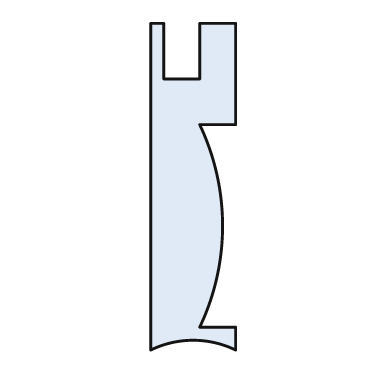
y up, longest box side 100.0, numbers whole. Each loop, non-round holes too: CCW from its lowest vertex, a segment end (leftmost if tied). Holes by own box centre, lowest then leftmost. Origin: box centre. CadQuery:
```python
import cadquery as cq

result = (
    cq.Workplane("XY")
    .moveTo(-13.0, -50.0)
    .threePointArc((0.0, -47.0), (13.0, -50.0))
    .lineTo(13.0, -43.0)
    .lineTo(2.0, -43.0)
    .threePointArc((9.0, -12.0), (2.0, 19.0))
    .lineTo(13.0, 19.0)
    .lineTo(13.0, 50.0)
    .lineTo(2.0, 50.0)
    .lineTo(2.0, 33.0)
    .lineTo(-9.0, 33.0)
    .lineTo(-9.0, 50.0)
    .lineTo(-13.0, 50.0)
    .close()
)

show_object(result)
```